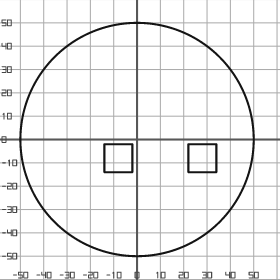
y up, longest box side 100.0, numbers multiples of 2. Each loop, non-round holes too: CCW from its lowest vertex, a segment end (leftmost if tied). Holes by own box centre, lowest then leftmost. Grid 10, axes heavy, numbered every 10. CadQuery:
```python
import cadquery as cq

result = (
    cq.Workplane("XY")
    .moveTo(0.0, 0.0)
    .circle(50.0)
    .moveTo(-14.0, -14.0)
    .lineTo(-2.0, -14.0)
    .lineTo(-2.0, -2.0)
    .lineTo(-14.0, -2.0)
    .close()
    .moveTo(22.0, -14.0)
    .lineTo(34.0, -14.0)
    .lineTo(34.0, -2.0)
    .lineTo(22.0, -2.0)
    .close()
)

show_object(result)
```